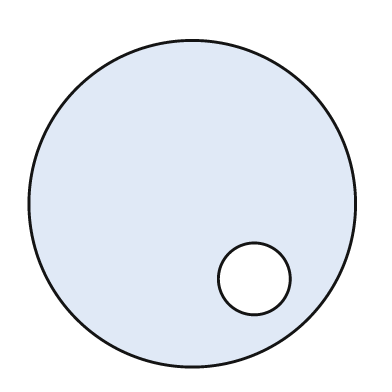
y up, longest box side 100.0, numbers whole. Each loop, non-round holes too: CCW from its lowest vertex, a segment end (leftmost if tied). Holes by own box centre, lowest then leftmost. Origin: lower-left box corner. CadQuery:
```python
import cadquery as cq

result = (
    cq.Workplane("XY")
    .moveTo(50.0, 50.0)
    .circle(50.0)
    .moveTo(69.0, 27.0)
    .circle(11.0)
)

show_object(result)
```